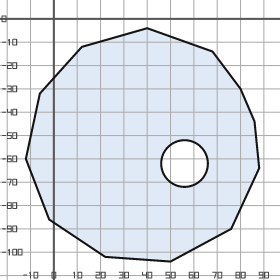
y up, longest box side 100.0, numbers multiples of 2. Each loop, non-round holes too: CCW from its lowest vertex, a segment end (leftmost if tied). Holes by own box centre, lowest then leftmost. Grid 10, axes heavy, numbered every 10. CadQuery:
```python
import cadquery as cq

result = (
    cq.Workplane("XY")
    .moveTo(50.0, -104.0)
    .lineTo(76.0, -90.0)
    .lineTo(88.0, -64.0)
    .lineTo(86.0, -44.0)
    .lineTo(80.0, -30.0)
    .lineTo(68.0, -14.0)
    .lineTo(40.0, -4.0)
    .lineTo(12.0, -12.0)
    .lineTo(-6.0, -32.0)
    .lineTo(-12.0, -60.0)
    .lineTo(-2.0, -86.0)
    .lineTo(22.0, -102.0)
    .close()
    .moveTo(56.0, -62.0)
    .circle(10.0)
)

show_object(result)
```